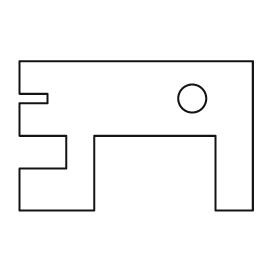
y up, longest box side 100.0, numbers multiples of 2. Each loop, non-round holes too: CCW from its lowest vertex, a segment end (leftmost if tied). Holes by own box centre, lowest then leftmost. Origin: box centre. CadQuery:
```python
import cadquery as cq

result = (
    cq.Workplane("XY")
    .moveTo(-50.0, -32.0)
    .lineTo(-18.0, -32.0)
    .lineTo(-18.0, 0.0)
    .lineTo(34.0, 0.0)
    .lineTo(34.0, -32.0)
    .lineTo(50.0, -32.0)
    .lineTo(50.0, 32.0)
    .lineTo(-50.0, 32.0)
    .lineTo(-50.0, 18.0)
    .lineTo(-38.0, 18.0)
    .lineTo(-38.0, 14.0)
    .lineTo(-50.0, 14.0)
    .lineTo(-50.0, 0.0)
    .lineTo(-30.0, 0.0)
    .lineTo(-30.0, -14.0)
    .lineTo(-50.0, -14.0)
    .close()
    .moveTo(24.0, 16.0)
    .circle(6.0)
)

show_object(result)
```